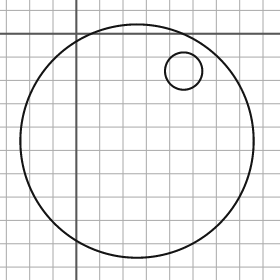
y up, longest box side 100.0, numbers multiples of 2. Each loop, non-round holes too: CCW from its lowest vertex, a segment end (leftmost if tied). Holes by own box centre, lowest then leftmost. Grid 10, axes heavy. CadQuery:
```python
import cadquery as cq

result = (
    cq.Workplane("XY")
    .moveTo(26.0, -46.0)
    .circle(50.0)
    .moveTo(46.0, -16.0)
    .circle(8.0)
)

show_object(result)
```